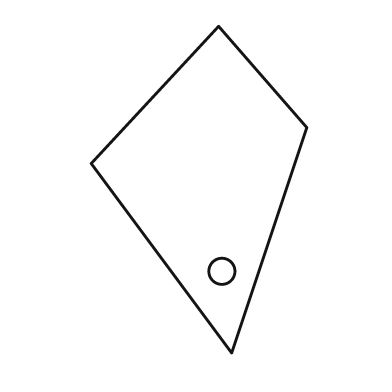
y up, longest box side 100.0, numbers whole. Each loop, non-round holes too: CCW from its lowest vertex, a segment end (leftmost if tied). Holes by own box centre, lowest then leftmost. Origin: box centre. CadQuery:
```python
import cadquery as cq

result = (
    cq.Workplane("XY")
    .moveTo(10.0, -50.0)
    .lineTo(33.0, 19.0)
    .lineTo(6.0, 50.0)
    .lineTo(-33.0, 8.0)
    .close()
    .moveTo(7.0, -25.0)
    .circle(4.0)
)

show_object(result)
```